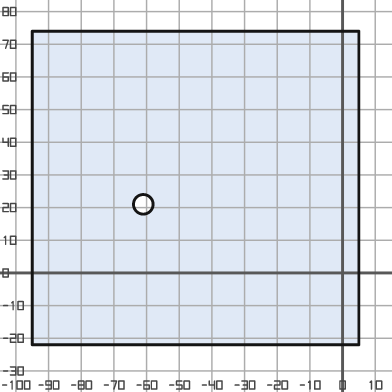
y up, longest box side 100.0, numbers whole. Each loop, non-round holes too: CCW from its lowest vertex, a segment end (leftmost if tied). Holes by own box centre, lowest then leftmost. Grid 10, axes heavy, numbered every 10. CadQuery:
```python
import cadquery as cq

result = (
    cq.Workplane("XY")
    .moveTo(-95.0, -22.0)
    .lineTo(5.0, -22.0)
    .lineTo(5.0, 74.0)
    .lineTo(-95.0, 74.0)
    .close()
    .moveTo(-61.0, 21.0)
    .circle(3.0)
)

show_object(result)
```